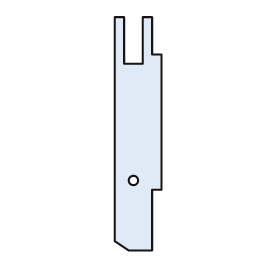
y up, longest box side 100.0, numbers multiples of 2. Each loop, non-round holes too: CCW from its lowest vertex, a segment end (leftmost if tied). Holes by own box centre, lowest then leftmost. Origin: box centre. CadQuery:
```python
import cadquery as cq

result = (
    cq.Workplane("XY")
    .moveTo(-4.0, -50.0)
    .lineTo(6.0, -50.0)
    .lineTo(6.0, -24.0)
    .lineTo(10.0, -24.0)
    .lineTo(10.0, 34.0)
    .lineTo(6.0, 34.0)
    .lineTo(6.0, 50.0)
    .lineTo(2.0, 50.0)
    .lineTo(2.0, 30.0)
    .lineTo(-6.0, 30.0)
    .lineTo(-6.0, 50.0)
    .lineTo(-10.0, 50.0)
    .lineTo(-10.0, -46.0)
    .close()
    .moveTo(-2.0, -20.0)
    .circle(2.0)
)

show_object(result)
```